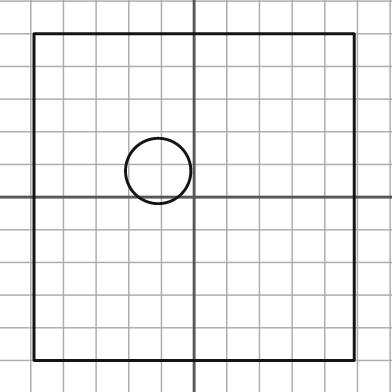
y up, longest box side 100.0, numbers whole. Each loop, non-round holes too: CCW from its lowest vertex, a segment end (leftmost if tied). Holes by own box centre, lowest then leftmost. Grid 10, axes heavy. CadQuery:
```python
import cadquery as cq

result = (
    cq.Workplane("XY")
    .moveTo(-49.0, -50.0)
    .lineTo(49.0, -50.0)
    .lineTo(49.0, 50.0)
    .lineTo(-49.0, 50.0)
    .close()
    .moveTo(-11.0, 8.0)
    .circle(10.0)
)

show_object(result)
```